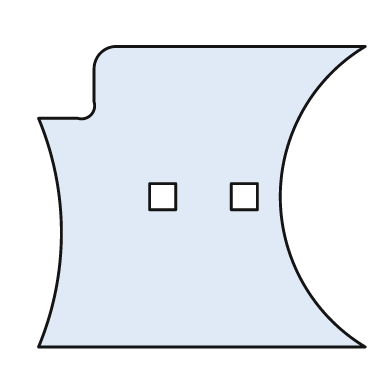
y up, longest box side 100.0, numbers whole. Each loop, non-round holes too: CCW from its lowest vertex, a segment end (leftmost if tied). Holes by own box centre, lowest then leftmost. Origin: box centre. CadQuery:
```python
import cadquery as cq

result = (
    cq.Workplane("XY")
    .moveTo(-50.0, -46.0)
    .lineTo(50.0, -46.0)
    .threePointArc((24.0, 0.0), (50.0, 46.0))
    .lineTo(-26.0, 46.0)
    .threePointArc((-31.0, 44.0), (-33.0, 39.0))
    .lineTo(-33.0, 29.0)
    .threePointArc((-34.0, 25.0), (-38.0, 24.0))
    .lineTo(-50.0, 24.0)
    .threePointArc((-43.0, -11.0), (-50.0, -46.0))
    .close()
    .moveTo(-16.0, -4.0)
    .lineTo(-8.0, -4.0)
    .lineTo(-8.0, 4.0)
    .lineTo(-16.0, 4.0)
    .close()
    .moveTo(9.0, -4.0)
    .lineTo(17.0, -4.0)
    .lineTo(17.0, 4.0)
    .lineTo(9.0, 4.0)
    .close()
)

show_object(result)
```